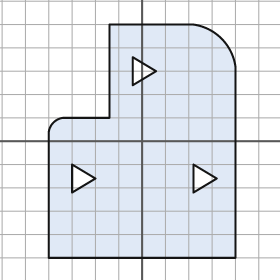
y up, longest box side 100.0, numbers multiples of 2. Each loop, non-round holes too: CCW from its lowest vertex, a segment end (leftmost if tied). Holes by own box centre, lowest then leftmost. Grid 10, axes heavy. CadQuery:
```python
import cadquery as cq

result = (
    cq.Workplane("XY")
    .moveTo(-40.0, -50.0)
    .lineTo(40.0, -50.0)
    .lineTo(40.0, 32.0)
    .threePointArc((34.0, 44.0), (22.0, 50.0))
    .lineTo(-14.0, 50.0)
    .lineTo(-14.0, 10.0)
    .lineTo(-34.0, 10.0)
    .threePointArc((-38.0, 8.0), (-40.0, 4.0))
    .close()
    .moveTo(-30.0, -22.0)
    .lineTo(-20.0, -16.0)
    .lineTo(-30.0, -10.0)
    .close()
    .moveTo(22.0, -22.0)
    .lineTo(32.0, -16.0)
    .lineTo(22.0, -10.0)
    .close()
    .moveTo(-4.0, 24.0)
    .lineTo(6.0, 30.0)
    .lineTo(-4.0, 36.0)
    .close()
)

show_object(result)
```